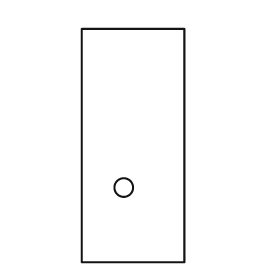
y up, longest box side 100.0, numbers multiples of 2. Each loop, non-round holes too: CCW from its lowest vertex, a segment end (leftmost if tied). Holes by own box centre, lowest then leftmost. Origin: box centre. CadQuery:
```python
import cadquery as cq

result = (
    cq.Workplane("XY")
    .moveTo(-22.0, -50.0)
    .lineTo(22.0, -50.0)
    .lineTo(22.0, 50.0)
    .lineTo(-22.0, 50.0)
    .close()
    .moveTo(-4.0, -18.0)
    .circle(4.0)
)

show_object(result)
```